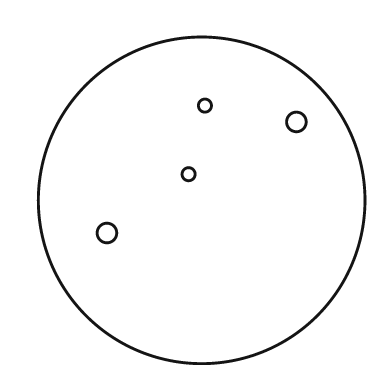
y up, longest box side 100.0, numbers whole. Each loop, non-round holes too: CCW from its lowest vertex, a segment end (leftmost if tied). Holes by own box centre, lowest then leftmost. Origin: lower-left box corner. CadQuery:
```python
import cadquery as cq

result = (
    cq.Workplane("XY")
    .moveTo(50.0, 50.0)
    .circle(50.0)
    .moveTo(21.0, 40.0)
    .circle(3.0)
    .moveTo(46.0, 58.0)
    .circle(2.0)
    .moveTo(79.0, 74.0)
    .circle(3.0)
    .moveTo(51.0, 79.0)
    .circle(2.0)
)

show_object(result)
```